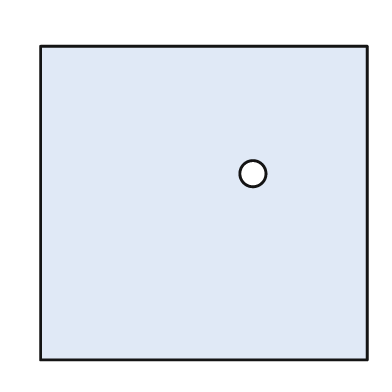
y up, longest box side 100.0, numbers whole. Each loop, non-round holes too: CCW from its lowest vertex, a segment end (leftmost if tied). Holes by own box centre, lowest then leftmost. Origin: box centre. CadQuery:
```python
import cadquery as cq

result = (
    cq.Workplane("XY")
    .moveTo(-50.0, -48.0)
    .lineTo(50.0, -48.0)
    .lineTo(50.0, 48.0)
    .lineTo(-50.0, 48.0)
    .close()
    .moveTo(15.0, 9.0)
    .circle(4.0)
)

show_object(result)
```